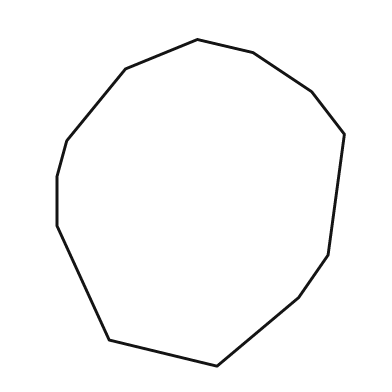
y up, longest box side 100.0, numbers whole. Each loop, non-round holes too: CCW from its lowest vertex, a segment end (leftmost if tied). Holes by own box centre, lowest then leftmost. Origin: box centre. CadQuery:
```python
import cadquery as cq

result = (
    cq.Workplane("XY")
    .moveTo(5.0, -50.0)
    .lineTo(30.0, -29.0)
    .lineTo(39.0, -16.0)
    .lineTo(44.0, 21.0)
    .lineTo(34.0, 34.0)
    .lineTo(16.0, 46.0)
    .lineTo(-1.0, 50.0)
    .lineTo(-23.0, 41.0)
    .lineTo(-41.0, 19.0)
    .lineTo(-44.0, 8.0)
    .lineTo(-44.0, -7.0)
    .lineTo(-28.0, -42.0)
    .close()
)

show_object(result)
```